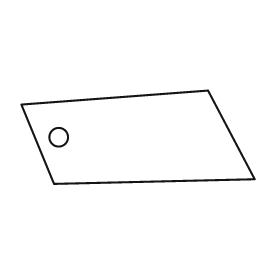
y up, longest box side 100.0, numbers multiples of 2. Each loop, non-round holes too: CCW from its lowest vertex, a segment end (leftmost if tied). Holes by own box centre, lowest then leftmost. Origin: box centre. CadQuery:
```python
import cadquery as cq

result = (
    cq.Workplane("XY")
    .moveTo(-36.0, -20.0)
    .lineTo(50.0, -18.0)
    .lineTo(30.0, 20.0)
    .lineTo(-50.0, 14.0)
    .close()
    .moveTo(-34.0, 0.0)
    .circle(4.0)
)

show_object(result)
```